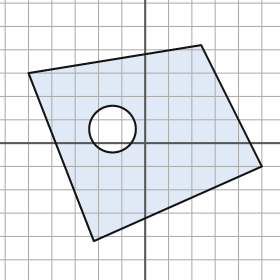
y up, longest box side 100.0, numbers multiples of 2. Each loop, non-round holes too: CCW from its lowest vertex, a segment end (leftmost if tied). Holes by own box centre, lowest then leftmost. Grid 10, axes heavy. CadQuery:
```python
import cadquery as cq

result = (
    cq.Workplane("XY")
    .moveTo(-22.0, -42.0)
    .lineTo(50.0, -10.0)
    .lineTo(24.0, 42.0)
    .lineTo(-50.0, 30.0)
    .close()
    .moveTo(-14.0, 6.0)
    .circle(10.0)
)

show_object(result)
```